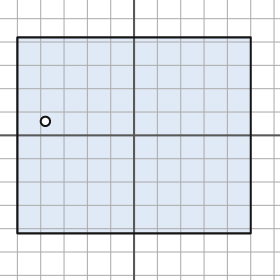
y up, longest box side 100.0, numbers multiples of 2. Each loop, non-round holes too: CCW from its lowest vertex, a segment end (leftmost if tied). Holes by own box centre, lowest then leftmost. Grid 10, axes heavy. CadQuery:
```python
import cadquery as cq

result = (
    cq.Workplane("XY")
    .moveTo(-50.0, -42.0)
    .lineTo(50.0, -42.0)
    .lineTo(50.0, 42.0)
    .lineTo(-50.0, 42.0)
    .close()
    .moveTo(-38.0, 6.0)
    .circle(2.0)
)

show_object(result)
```